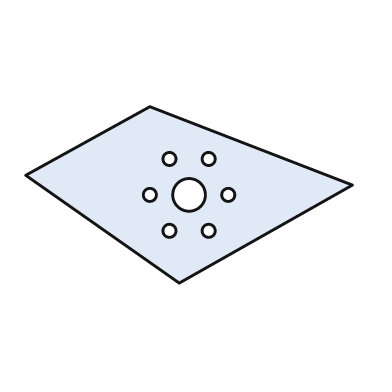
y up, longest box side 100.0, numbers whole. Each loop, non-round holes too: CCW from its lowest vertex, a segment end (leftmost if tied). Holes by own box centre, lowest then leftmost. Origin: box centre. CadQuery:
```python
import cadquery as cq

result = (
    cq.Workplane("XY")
    .moveTo(-3.0, -27.0)
    .lineTo(50.0, 3.0)
    .lineTo(-12.0, 27.0)
    .lineTo(-50.0, 6.0)
    .close()
    .moveTo(-6.0, -11.0)
    .circle(2.0)
    .moveTo(6.0, -11.0)
    .circle(2.0)
    .moveTo(-12.0, 0.0)
    .circle(2.0)
    .moveTo(0.0, 0.0)
    .circle(5.0)
    .moveTo(12.0, 0.0)
    .circle(2.0)
    .moveTo(-6.0, 11.0)
    .circle(2.0)
    .moveTo(6.0, 11.0)
    .circle(2.0)
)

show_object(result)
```